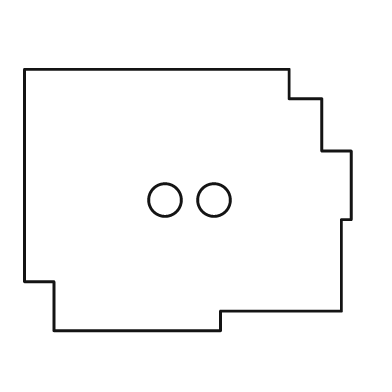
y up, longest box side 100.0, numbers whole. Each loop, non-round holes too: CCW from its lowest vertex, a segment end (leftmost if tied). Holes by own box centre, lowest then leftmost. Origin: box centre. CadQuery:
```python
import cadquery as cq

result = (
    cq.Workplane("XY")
    .moveTo(-41.0, -40.0)
    .lineTo(10.0, -40.0)
    .lineTo(10.0, -34.0)
    .lineTo(47.0, -34.0)
    .lineTo(47.0, -6.0)
    .lineTo(50.0, -6.0)
    .lineTo(50.0, 15.0)
    .lineTo(41.0, 15.0)
    .lineTo(41.0, 31.0)
    .lineTo(31.0, 31.0)
    .lineTo(31.0, 40.0)
    .lineTo(-50.0, 40.0)
    .lineTo(-50.0, -25.0)
    .lineTo(-41.0, -25.0)
    .close()
    .moveTo(-7.0, 0.0)
    .circle(5.0)
    .moveTo(8.0, 0.0)
    .circle(5.0)
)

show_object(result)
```